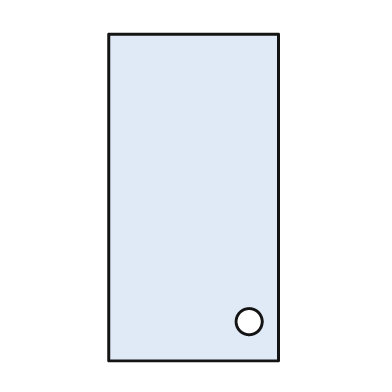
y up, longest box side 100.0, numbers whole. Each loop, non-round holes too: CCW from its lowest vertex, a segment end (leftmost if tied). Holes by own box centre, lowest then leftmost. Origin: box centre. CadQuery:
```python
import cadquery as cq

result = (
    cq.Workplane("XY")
    .moveTo(-26.0, -50.0)
    .lineTo(26.0, -50.0)
    .lineTo(26.0, 50.0)
    .lineTo(-26.0, 50.0)
    .close()
    .moveTo(17.0, -38.0)
    .circle(4.0)
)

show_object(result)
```